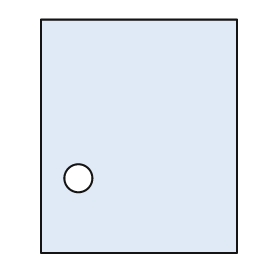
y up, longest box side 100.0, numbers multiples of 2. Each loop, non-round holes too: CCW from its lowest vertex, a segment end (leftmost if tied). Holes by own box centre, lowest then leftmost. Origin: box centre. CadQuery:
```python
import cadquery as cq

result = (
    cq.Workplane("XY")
    .moveTo(-42.0, -50.0)
    .lineTo(42.0, -50.0)
    .lineTo(42.0, 50.0)
    .lineTo(-42.0, 50.0)
    .close()
    .moveTo(-26.0, -18.0)
    .circle(6.0)
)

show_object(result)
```